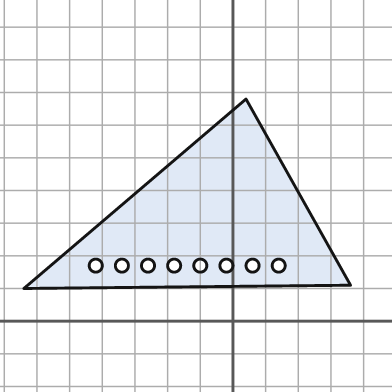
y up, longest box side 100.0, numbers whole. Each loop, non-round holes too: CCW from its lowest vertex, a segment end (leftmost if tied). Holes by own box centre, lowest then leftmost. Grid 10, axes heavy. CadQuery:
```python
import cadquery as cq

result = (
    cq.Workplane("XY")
    .moveTo(-64.0, 10.0)
    .lineTo(36.0, 11.0)
    .lineTo(4.0, 68.0)
    .close()
    .moveTo(-42.0, 17.0)
    .circle(2.0)
    .moveTo(-34.0, 17.0)
    .circle(2.0)
    .moveTo(-26.0, 17.0)
    .circle(2.0)
    .moveTo(-18.0, 17.0)
    .circle(2.0)
    .moveTo(-10.0, 17.0)
    .circle(2.0)
    .moveTo(-2.0, 17.0)
    .circle(2.0)
    .moveTo(6.0, 17.0)
    .circle(2.0)
    .moveTo(14.0, 17.0)
    .circle(2.0)
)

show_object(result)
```